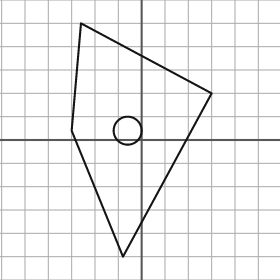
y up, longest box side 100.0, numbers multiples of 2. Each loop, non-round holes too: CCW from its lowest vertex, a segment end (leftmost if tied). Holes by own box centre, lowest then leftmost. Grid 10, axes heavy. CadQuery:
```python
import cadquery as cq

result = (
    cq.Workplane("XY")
    .moveTo(-8.0, -50.0)
    .lineTo(30.0, 20.0)
    .lineTo(-26.0, 50.0)
    .lineTo(-30.0, 4.0)
    .close()
    .moveTo(-6.0, 4.0)
    .circle(6.0)
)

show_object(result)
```